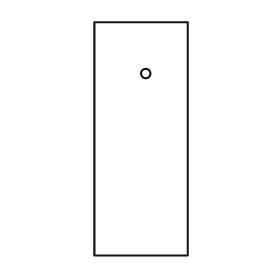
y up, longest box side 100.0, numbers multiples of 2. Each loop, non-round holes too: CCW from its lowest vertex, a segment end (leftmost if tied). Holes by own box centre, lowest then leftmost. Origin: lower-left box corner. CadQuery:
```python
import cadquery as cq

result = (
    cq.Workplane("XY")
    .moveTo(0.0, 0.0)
    .lineTo(40.0, 0.0)
    .lineTo(40.0, 100.0)
    .lineTo(0.0, 100.0)
    .close()
    .moveTo(22.0, 78.0)
    .circle(2.0)
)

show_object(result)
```